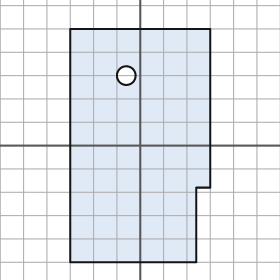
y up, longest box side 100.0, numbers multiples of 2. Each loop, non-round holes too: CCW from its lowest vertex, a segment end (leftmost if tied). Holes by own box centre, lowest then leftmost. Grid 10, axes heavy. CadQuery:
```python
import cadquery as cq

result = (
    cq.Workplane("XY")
    .moveTo(-30.0, -50.0)
    .lineTo(24.0, -50.0)
    .lineTo(24.0, -18.0)
    .lineTo(30.0, -18.0)
    .lineTo(30.0, 50.0)
    .lineTo(-30.0, 50.0)
    .close()
    .moveTo(-6.0, 30.0)
    .circle(4.0)
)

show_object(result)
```